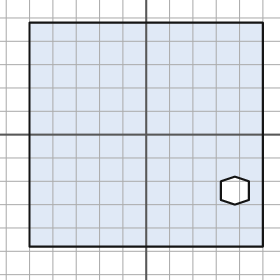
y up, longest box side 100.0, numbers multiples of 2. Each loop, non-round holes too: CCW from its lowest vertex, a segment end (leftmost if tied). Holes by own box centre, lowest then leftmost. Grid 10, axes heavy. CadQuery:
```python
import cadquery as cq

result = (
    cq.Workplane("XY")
    .moveTo(-50.0, -48.0)
    .lineTo(50.0, -48.0)
    .lineTo(50.0, 48.0)
    .lineTo(-50.0, 48.0)
    .close()
    .moveTo(38.0, -30.0)
    .lineTo(44.0, -28.0)
    .lineTo(44.0, -20.0)
    .lineTo(38.0, -18.0)
    .lineTo(32.0, -20.0)
    .lineTo(32.0, -28.0)
    .close()
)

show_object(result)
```